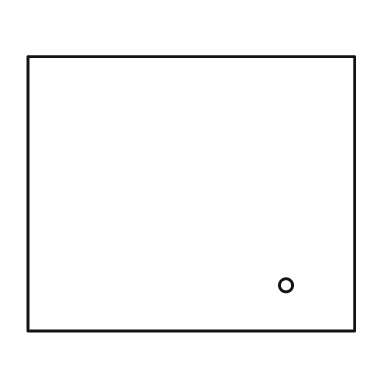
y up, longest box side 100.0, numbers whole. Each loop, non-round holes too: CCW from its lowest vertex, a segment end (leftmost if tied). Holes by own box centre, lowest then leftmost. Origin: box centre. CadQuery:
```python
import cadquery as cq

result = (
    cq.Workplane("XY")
    .moveTo(-50.0, -42.0)
    .lineTo(50.0, -42.0)
    .lineTo(50.0, 42.0)
    .lineTo(-50.0, 42.0)
    .close()
    .moveTo(29.0, -28.0)
    .circle(2.0)
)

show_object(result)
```